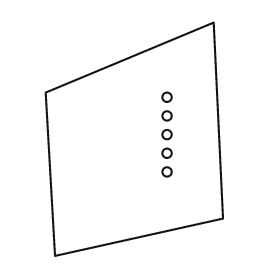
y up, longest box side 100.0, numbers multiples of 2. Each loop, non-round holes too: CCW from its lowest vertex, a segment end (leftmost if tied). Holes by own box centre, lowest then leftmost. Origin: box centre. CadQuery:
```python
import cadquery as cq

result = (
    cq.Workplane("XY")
    .moveTo(-34.0, -50.0)
    .lineTo(38.0, -34.0)
    .lineTo(34.0, 50.0)
    .lineTo(-38.0, 20.0)
    .close()
    .moveTo(14.0, -14.0)
    .circle(2.0)
    .moveTo(14.0, -6.0)
    .circle(2.0)
    .moveTo(14.0, 2.0)
    .circle(2.0)
    .moveTo(14.0, 10.0)
    .circle(2.0)
    .moveTo(14.0, 18.0)
    .circle(2.0)
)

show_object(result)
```